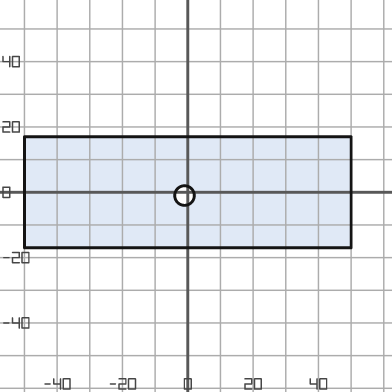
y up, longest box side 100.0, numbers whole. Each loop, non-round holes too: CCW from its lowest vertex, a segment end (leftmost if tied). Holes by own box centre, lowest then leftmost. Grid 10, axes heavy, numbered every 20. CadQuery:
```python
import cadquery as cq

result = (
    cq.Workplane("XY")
    .moveTo(-50.0, -17.0)
    .lineTo(50.0, -17.0)
    .lineTo(50.0, 17.0)
    .lineTo(-50.0, 17.0)
    .close()
    .moveTo(-1.0, -1.0)
    .circle(3.0)
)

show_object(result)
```